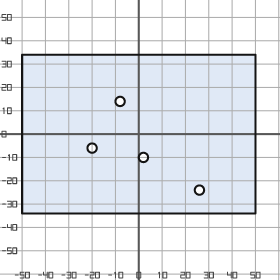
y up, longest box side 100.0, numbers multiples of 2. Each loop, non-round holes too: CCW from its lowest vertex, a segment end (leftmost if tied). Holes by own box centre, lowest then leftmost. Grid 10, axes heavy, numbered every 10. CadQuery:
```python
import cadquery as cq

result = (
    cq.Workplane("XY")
    .moveTo(-50.0, -34.0)
    .lineTo(50.0, -34.0)
    .lineTo(50.0, 34.0)
    .lineTo(-50.0, 34.0)
    .close()
    .moveTo(26.0, -24.0)
    .circle(2.0)
    .moveTo(2.0, -10.0)
    .circle(2.0)
    .moveTo(-20.0, -6.0)
    .circle(2.0)
    .moveTo(-8.0, 14.0)
    .circle(2.0)
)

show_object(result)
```